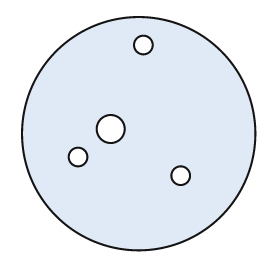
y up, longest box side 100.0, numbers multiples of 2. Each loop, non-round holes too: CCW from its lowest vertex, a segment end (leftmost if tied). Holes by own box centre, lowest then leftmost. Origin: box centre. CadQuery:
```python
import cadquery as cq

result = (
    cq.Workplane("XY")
    .moveTo(0.0, 0.0)
    .circle(50.0)
    .moveTo(18.0, -18.0)
    .circle(4.0)
    .moveTo(-26.0, -10.0)
    .circle(4.0)
    .moveTo(-12.0, 2.0)
    .circle(6.0)
    .moveTo(2.0, 38.0)
    .circle(4.0)
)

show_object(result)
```